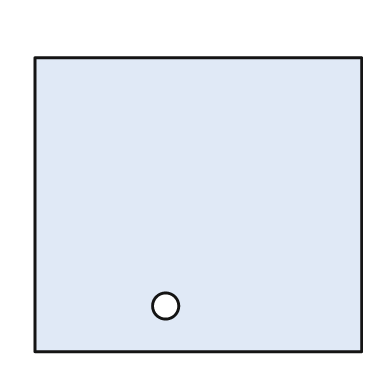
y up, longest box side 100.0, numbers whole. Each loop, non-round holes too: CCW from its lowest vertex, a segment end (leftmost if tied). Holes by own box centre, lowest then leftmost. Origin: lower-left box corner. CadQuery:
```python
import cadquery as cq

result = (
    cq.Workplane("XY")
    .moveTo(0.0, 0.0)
    .lineTo(100.0, 0.0)
    .lineTo(100.0, 90.0)
    .lineTo(0.0, 90.0)
    .close()
    .moveTo(40.0, 14.0)
    .circle(4.0)
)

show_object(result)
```